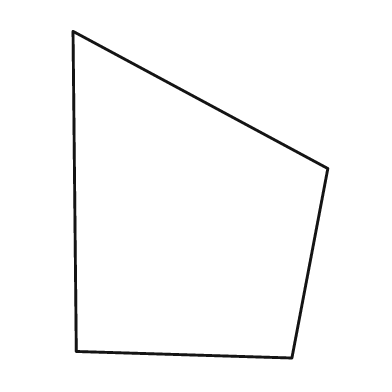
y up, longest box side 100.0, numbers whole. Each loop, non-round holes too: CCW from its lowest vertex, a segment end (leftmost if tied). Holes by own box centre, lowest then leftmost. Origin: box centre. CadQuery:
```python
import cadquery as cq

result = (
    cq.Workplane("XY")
    .moveTo(28.0, -50.0)
    .lineTo(39.0, 8.0)
    .lineTo(-39.0, 50.0)
    .lineTo(-38.0, -48.0)
    .close()
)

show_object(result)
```